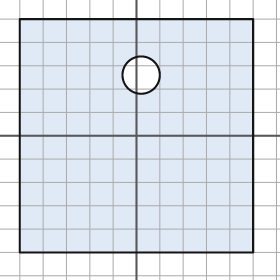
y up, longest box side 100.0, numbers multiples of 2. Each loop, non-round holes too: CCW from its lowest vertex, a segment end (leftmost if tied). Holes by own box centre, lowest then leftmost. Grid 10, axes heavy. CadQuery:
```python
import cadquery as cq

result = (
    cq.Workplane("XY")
    .moveTo(-50.0, -50.0)
    .lineTo(50.0, -50.0)
    .lineTo(50.0, 50.0)
    .lineTo(-50.0, 50.0)
    .close()
    .moveTo(2.0, 26.0)
    .circle(8.0)
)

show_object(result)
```